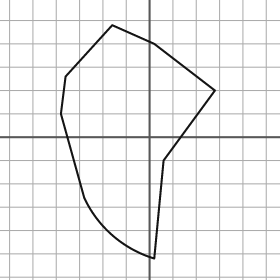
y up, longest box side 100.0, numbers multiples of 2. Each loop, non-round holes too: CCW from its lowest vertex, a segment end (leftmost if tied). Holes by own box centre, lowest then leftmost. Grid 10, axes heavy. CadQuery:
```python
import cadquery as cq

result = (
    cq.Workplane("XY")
    .moveTo(2.0, -52.0)
    .lineTo(6.0, -10.0)
    .lineTo(28.0, 20.0)
    .lineTo(2.0, 40.0)
    .lineTo(-16.0, 48.0)
    .lineTo(-36.0, 26.0)
    .lineTo(-38.0, 10.0)
    .lineTo(-28.0, -26.0)
    .threePointArc((-16.0, -42.0), (2.0, -52.0))
    .close()
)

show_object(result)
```